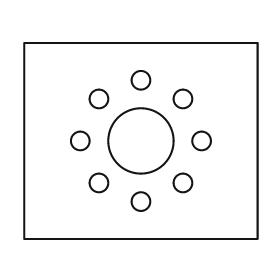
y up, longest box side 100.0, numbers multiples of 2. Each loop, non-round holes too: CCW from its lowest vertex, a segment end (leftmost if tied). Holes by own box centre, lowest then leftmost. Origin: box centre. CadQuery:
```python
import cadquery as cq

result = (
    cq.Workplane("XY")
    .moveTo(-50.0, -42.0)
    .lineTo(50.0, -42.0)
    .lineTo(50.0, 42.0)
    .lineTo(-50.0, 42.0)
    .close()
    .moveTo(0.0, -26.0)
    .circle(4.0)
    .moveTo(-18.0, -18.0)
    .circle(4.0)
    .moveTo(18.0, -18.0)
    .circle(4.0)
    .moveTo(-26.0, 0.0)
    .circle(4.0)
    .moveTo(0.0, 0.0)
    .circle(14.0)
    .moveTo(26.0, 0.0)
    .circle(4.0)
    .moveTo(-18.0, 18.0)
    .circle(4.0)
    .moveTo(18.0, 18.0)
    .circle(4.0)
    .moveTo(0.0, 26.0)
    .circle(4.0)
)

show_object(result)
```